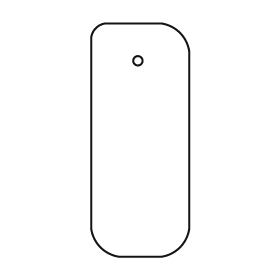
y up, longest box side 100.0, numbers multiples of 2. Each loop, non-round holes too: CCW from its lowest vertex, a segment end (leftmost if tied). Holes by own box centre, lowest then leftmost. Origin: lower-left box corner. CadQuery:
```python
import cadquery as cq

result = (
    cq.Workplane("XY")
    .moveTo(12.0, 0.0)
    .lineTo(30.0, 0.0)
    .threePointArc((38.0, 4.0), (42.0, 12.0))
    .lineTo(42.0, 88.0)
    .threePointArc((38.0, 96.0), (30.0, 100.0))
    .lineTo(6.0, 100.0)
    .threePointArc((2.0, 98.0), (0.0, 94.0))
    .lineTo(0.0, 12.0)
    .threePointArc((4.0, 4.0), (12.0, 0.0))
    .close()
    .moveTo(20.0, 84.0)
    .circle(2.0)
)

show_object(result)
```